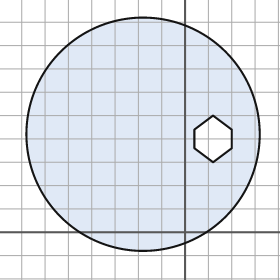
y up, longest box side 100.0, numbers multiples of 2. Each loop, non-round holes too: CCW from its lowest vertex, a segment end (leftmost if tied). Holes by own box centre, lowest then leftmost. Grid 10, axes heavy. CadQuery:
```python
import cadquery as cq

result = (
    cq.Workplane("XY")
    .moveTo(-18.0, 42.0)
    .circle(50.0)
    .moveTo(12.0, 30.0)
    .lineTo(20.0, 36.0)
    .lineTo(20.0, 44.0)
    .lineTo(12.0, 50.0)
    .lineTo(4.0, 44.0)
    .lineTo(4.0, 36.0)
    .close()
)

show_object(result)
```